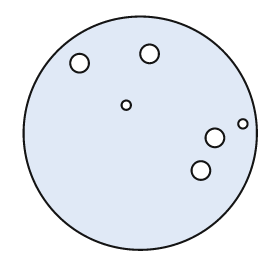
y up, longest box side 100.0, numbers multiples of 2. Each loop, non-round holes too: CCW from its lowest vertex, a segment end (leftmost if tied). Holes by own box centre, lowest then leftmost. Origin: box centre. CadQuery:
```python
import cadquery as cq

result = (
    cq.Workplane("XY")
    .moveTo(0.0, 0.0)
    .circle(50.0)
    .moveTo(26.0, -16.0)
    .circle(4.0)
    .moveTo(32.0, -2.0)
    .circle(4.0)
    .moveTo(44.0, 4.0)
    .circle(2.0)
    .moveTo(-6.0, 12.0)
    .circle(2.0)
    .moveTo(-26.0, 30.0)
    .circle(4.0)
    .moveTo(4.0, 34.0)
    .circle(4.0)
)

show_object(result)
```